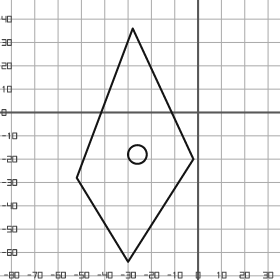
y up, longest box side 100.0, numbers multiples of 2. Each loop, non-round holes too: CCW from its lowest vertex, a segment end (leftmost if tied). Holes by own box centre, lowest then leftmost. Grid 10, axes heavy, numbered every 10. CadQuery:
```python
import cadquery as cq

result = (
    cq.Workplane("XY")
    .moveTo(-30.0, -64.0)
    .lineTo(-2.0, -20.0)
    .lineTo(-28.0, 36.0)
    .lineTo(-52.0, -28.0)
    .close()
    .moveTo(-26.0, -18.0)
    .circle(4.0)
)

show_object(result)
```